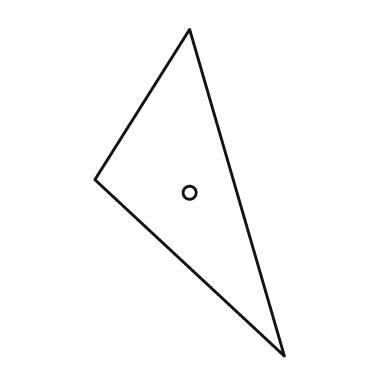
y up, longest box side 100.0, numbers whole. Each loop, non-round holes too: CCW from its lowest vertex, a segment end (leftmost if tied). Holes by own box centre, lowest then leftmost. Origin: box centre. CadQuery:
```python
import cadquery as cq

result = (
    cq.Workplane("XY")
    .moveTo(29.0, -50.0)
    .lineTo(0.0, 50.0)
    .lineTo(-29.0, 4.0)
    .close()
    .moveTo(0.0, 0.0)
    .circle(2.0)
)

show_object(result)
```